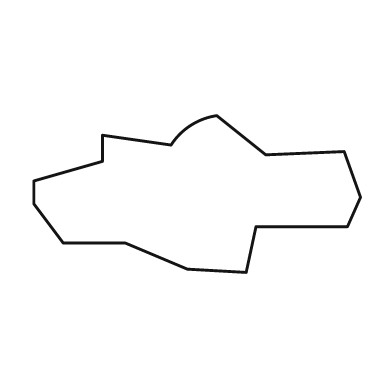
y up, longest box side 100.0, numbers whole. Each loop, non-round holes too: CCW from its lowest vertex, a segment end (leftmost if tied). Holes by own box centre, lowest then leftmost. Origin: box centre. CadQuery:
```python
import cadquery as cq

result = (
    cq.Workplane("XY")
    .moveTo(15.0, -24.0)
    .lineTo(18.0, -10.0)
    .lineTo(46.0, -10.0)
    .lineTo(50.0, -1.0)
    .lineTo(45.0, 13.0)
    .lineTo(21.0, 12.0)
    .lineTo(6.0, 24.0)
    .threePointArc((-2.0, 21.0), (-8.0, 15.0))
    .lineTo(-29.0, 18.0)
    .lineTo(-29.0, 10.0)
    .lineTo(-50.0, 4.0)
    .lineTo(-50.0, -3.0)
    .lineTo(-41.0, -15.0)
    .lineTo(-22.0, -15.0)
    .lineTo(-3.0, -23.0)
    .close()
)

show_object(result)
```